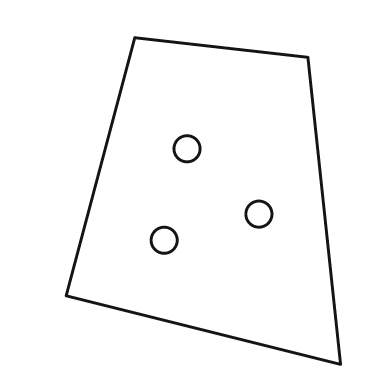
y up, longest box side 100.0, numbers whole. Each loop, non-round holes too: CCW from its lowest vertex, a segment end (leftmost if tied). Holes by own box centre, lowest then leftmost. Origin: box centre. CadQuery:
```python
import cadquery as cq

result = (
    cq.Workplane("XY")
    .moveTo(42.0, -50.0)
    .lineTo(32.0, 44.0)
    .lineTo(-21.0, 50.0)
    .lineTo(-42.0, -29.0)
    .close()
    .moveTo(-12.0, -12.0)
    .circle(4.0)
    .moveTo(17.0, -4.0)
    .circle(4.0)
    .moveTo(-5.0, 16.0)
    .circle(4.0)
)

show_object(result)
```